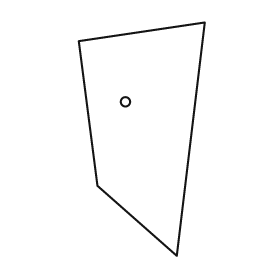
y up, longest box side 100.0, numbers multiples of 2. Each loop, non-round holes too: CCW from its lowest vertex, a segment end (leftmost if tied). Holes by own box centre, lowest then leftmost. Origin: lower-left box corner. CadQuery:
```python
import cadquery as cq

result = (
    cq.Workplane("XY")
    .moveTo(42.0, 0.0)
    .lineTo(54.0, 100.0)
    .lineTo(0.0, 92.0)
    .lineTo(8.0, 30.0)
    .close()
    .moveTo(20.0, 66.0)
    .circle(2.0)
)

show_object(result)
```